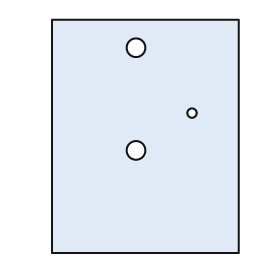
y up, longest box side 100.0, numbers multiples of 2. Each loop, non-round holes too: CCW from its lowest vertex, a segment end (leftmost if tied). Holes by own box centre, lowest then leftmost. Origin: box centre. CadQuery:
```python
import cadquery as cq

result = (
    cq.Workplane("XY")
    .moveTo(-40.0, -50.0)
    .lineTo(40.0, -50.0)
    .lineTo(40.0, 50.0)
    .lineTo(-40.0, 50.0)
    .close()
    .moveTo(-4.0, -6.0)
    .circle(4.0)
    .moveTo(20.0, 10.0)
    .circle(2.0)
    .moveTo(-4.0, 38.0)
    .circle(4.0)
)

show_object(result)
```